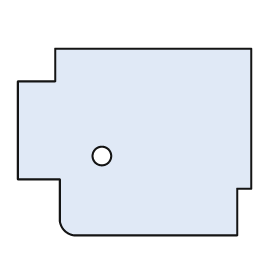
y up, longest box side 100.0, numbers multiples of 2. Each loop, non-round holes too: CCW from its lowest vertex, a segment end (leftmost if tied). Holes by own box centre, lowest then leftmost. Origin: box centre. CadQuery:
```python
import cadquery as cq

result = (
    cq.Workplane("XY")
    .moveTo(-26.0, -40.0)
    .lineTo(44.0, -40.0)
    .lineTo(44.0, -20.0)
    .lineTo(50.0, -20.0)
    .lineTo(50.0, 40.0)
    .lineTo(-34.0, 40.0)
    .lineTo(-34.0, 26.0)
    .lineTo(-50.0, 26.0)
    .lineTo(-50.0, -16.0)
    .lineTo(-32.0, -16.0)
    .lineTo(-32.0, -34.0)
    .threePointArc((-30.0, -38.0), (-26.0, -40.0))
    .close()
    .moveTo(-14.0, -6.0)
    .circle(4.0)
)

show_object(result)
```